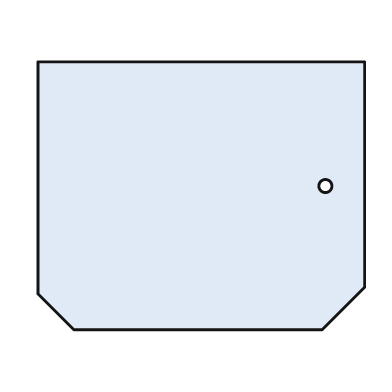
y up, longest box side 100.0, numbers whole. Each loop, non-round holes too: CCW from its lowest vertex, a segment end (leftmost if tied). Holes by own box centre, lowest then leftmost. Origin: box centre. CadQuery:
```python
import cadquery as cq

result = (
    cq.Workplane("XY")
    .moveTo(-39.0, -41.0)
    .lineTo(37.0, -41.0)
    .lineTo(50.0, -28.0)
    .lineTo(50.0, 41.0)
    .lineTo(-50.0, 41.0)
    .lineTo(-50.0, -30.0)
    .close()
    .moveTo(38.0, 3.0)
    .circle(2.0)
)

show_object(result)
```